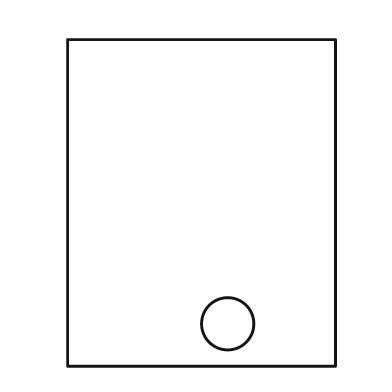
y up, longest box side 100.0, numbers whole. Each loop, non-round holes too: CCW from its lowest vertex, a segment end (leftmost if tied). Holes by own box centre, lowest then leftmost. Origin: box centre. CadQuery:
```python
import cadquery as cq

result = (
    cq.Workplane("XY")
    .moveTo(-41.0, -50.0)
    .lineTo(41.0, -50.0)
    .lineTo(41.0, 50.0)
    .lineTo(-41.0, 50.0)
    .close()
    .moveTo(8.0, -37.0)
    .circle(8.0)
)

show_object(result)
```